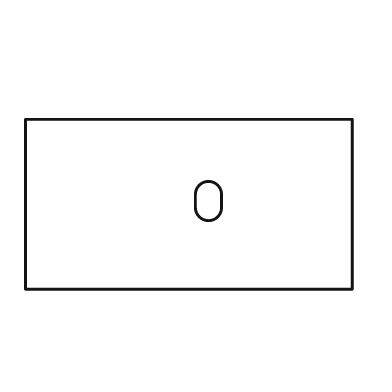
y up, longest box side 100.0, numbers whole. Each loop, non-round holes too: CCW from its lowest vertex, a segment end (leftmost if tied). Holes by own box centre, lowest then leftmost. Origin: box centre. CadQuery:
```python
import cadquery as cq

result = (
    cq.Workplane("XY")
    .moveTo(-50.0, -26.0)
    .lineTo(50.0, -26.0)
    .lineTo(50.0, 26.0)
    .lineTo(-50.0, 26.0)
    .close()
    .moveTo(2.0, -1.0)
    .threePointArc((6.0, -5.0), (10.0, -1.0))
    .lineTo(10.0, 3.0)
    .threePointArc((6.0, 7.0), (2.0, 3.0))
    .close()
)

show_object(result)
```